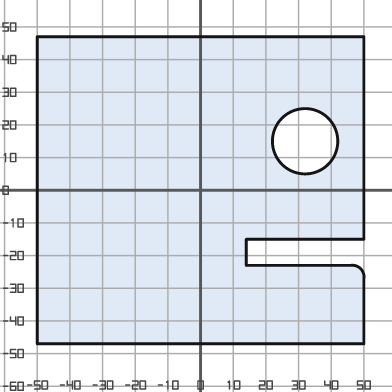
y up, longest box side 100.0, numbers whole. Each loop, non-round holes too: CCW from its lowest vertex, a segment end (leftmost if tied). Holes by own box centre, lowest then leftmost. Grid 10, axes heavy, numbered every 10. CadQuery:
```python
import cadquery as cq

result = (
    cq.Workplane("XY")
    .moveTo(-50.0, -47.0)
    .lineTo(50.0, -47.0)
    .lineTo(50.0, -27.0)
    .threePointArc((49.0, -24.0), (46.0, -23.0))
    .lineTo(14.0, -23.0)
    .lineTo(14.0, -15.0)
    .lineTo(50.0, -15.0)
    .lineTo(50.0, 47.0)
    .lineTo(-50.0, 47.0)
    .close()
    .moveTo(32.0, 15.0)
    .circle(10.0)
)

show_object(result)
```